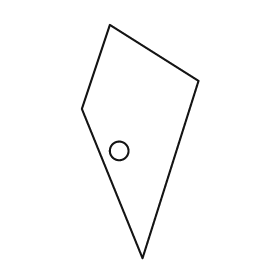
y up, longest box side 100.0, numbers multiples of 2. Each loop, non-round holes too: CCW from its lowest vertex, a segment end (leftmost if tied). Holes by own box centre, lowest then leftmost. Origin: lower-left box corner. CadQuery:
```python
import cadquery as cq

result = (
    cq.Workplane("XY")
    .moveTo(26.0, 0.0)
    .lineTo(50.0, 76.0)
    .lineTo(12.0, 100.0)
    .lineTo(0.0, 64.0)
    .close()
    .moveTo(16.0, 46.0)
    .circle(4.0)
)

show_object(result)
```